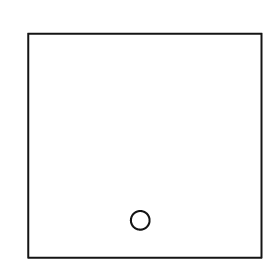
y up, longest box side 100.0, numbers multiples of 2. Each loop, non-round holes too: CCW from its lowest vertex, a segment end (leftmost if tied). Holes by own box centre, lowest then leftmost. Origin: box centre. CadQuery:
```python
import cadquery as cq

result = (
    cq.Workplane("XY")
    .moveTo(-50.0, -48.0)
    .lineTo(50.0, -48.0)
    .lineTo(50.0, 48.0)
    .lineTo(-50.0, 48.0)
    .close()
    .moveTo(-2.0, -32.0)
    .circle(4.0)
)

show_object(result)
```